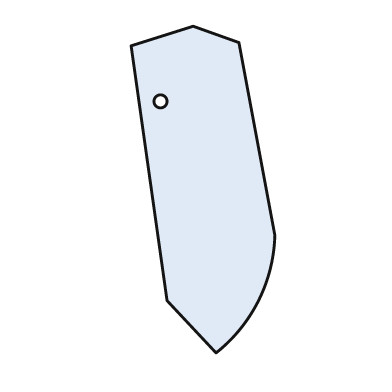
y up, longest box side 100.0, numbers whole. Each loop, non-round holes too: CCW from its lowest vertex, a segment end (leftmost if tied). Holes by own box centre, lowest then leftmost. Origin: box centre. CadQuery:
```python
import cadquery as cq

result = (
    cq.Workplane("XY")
    .moveTo(4.0, -50.0)
    .threePointArc((17.0, -34.0), (22.0, -14.0))
    .lineTo(11.0, 45.0)
    .lineTo(-3.0, 50.0)
    .lineTo(-22.0, 44.0)
    .lineTo(-11.0, -34.0)
    .close()
    .moveTo(-13.0, 27.0)
    .circle(2.0)
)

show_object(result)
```